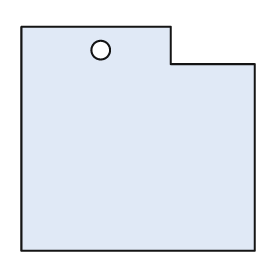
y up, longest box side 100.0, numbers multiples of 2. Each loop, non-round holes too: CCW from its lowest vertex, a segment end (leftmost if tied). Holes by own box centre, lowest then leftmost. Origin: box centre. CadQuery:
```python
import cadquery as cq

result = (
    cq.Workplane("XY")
    .moveTo(-50.0, -48.0)
    .lineTo(50.0, -48.0)
    .lineTo(50.0, 32.0)
    .lineTo(14.0, 32.0)
    .lineTo(14.0, 48.0)
    .lineTo(-50.0, 48.0)
    .close()
    .moveTo(-16.0, 38.0)
    .circle(4.0)
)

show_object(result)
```